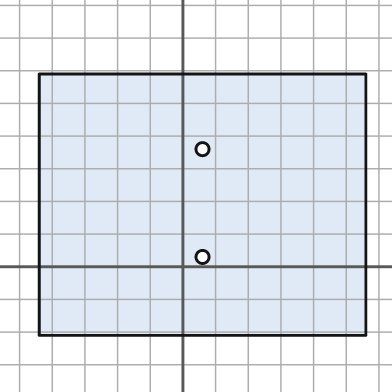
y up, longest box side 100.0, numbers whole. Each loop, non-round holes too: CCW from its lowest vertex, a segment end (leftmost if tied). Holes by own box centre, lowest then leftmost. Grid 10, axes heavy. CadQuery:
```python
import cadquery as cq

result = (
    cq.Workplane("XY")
    .moveTo(-44.0, -21.0)
    .lineTo(56.0, -21.0)
    .lineTo(56.0, 59.0)
    .lineTo(-44.0, 59.0)
    .close()
    .moveTo(6.0, 3.0)
    .circle(2.0)
    .moveTo(6.0, 36.0)
    .circle(2.0)
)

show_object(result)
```